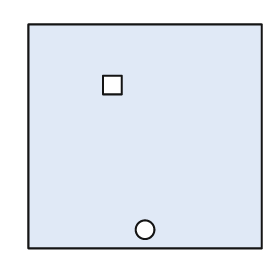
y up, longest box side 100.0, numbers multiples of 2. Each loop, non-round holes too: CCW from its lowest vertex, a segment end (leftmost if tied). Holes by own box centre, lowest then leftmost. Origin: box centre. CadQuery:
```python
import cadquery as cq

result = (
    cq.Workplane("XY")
    .moveTo(-50.0, -48.0)
    .lineTo(50.0, -48.0)
    .lineTo(50.0, 48.0)
    .lineTo(-50.0, 48.0)
    .close()
    .moveTo(0.0, -40.0)
    .circle(4.0)
    .moveTo(-18.0, 18.0)
    .lineTo(-10.0, 18.0)
    .lineTo(-10.0, 26.0)
    .lineTo(-18.0, 26.0)
    .close()
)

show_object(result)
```